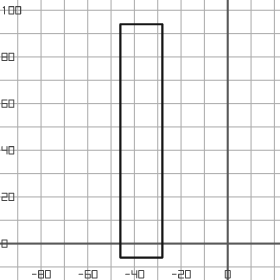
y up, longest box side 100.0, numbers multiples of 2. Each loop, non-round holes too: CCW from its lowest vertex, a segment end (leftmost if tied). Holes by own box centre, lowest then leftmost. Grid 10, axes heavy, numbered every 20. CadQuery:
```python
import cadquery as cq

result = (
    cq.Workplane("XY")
    .moveTo(-46.0, -6.0)
    .lineTo(-28.0, -6.0)
    .lineTo(-28.0, 94.0)
    .lineTo(-46.0, 94.0)
    .close()
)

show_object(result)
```